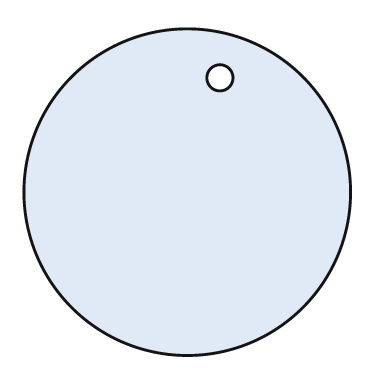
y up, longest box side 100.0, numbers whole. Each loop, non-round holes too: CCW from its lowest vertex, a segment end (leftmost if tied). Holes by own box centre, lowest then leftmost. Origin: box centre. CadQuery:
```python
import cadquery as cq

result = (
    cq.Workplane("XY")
    .moveTo(0.0, 0.0)
    .circle(50.0)
    .moveTo(10.0, 35.0)
    .circle(4.0)
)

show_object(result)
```